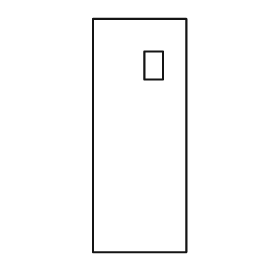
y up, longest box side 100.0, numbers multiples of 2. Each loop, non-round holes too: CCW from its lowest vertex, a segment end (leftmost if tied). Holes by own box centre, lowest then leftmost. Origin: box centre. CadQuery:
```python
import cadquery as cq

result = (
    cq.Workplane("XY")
    .moveTo(-20.0, -50.0)
    .lineTo(20.0, -50.0)
    .lineTo(20.0, 50.0)
    .lineTo(-20.0, 50.0)
    .close()
    .moveTo(2.0, 24.0)
    .lineTo(10.0, 24.0)
    .lineTo(10.0, 36.0)
    .lineTo(2.0, 36.0)
    .close()
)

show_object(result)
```